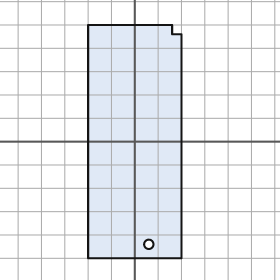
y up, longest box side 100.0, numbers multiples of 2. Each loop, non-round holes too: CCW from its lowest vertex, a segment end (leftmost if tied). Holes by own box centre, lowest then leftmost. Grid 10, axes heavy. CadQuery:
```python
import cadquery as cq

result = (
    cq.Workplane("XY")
    .moveTo(-20.0, -50.0)
    .lineTo(20.0, -50.0)
    .lineTo(20.0, 46.0)
    .lineTo(16.0, 46.0)
    .lineTo(16.0, 50.0)
    .lineTo(-20.0, 50.0)
    .close()
    .moveTo(6.0, -44.0)
    .circle(2.0)
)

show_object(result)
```